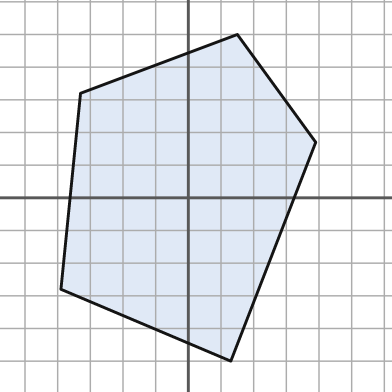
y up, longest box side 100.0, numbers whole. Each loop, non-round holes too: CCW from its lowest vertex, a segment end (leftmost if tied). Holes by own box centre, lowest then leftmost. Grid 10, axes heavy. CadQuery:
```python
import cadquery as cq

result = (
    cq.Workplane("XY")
    .moveTo(13.0, -50.0)
    .lineTo(39.0, 17.0)
    .lineTo(15.0, 50.0)
    .lineTo(-33.0, 32.0)
    .lineTo(-39.0, -28.0)
    .close()
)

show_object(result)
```